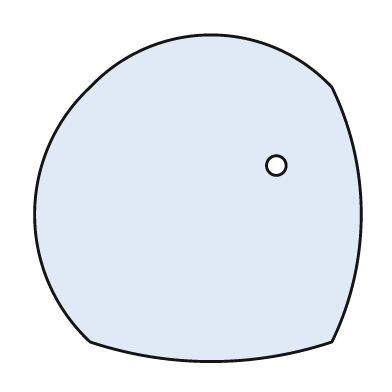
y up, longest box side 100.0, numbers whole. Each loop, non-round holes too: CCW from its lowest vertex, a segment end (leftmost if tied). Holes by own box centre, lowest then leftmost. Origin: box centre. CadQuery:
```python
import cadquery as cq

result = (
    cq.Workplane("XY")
    .moveTo(-33.0, -44.0)
    .threePointArc((4.0, -50.0), (41.0, -44.0))
    .threePointArc((50.0, -5.0), (41.0, 34.0))
    .threePointArc((4.0, 50.0), (-33.0, 34.0))
    .threePointArc((-50.0, -5.0), (-33.0, -44.0))
    .close()
    .moveTo(24.0, 10.0)
    .circle(3.0)
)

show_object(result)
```